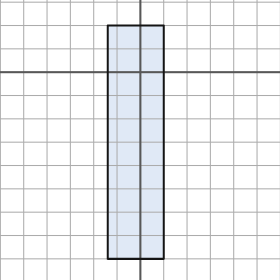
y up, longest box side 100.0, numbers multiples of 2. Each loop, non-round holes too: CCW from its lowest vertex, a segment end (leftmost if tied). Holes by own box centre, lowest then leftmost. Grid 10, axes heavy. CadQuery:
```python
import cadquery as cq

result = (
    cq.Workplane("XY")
    .moveTo(-14.0, -80.0)
    .lineTo(10.0, -80.0)
    .lineTo(10.0, 20.0)
    .lineTo(-14.0, 20.0)
    .close()
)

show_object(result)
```